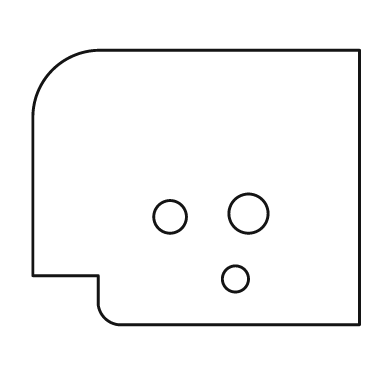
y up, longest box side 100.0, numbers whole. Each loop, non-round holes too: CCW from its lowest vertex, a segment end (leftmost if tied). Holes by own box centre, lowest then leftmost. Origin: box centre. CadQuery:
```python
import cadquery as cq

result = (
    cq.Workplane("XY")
    .moveTo(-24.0, -42.0)
    .lineTo(50.0, -42.0)
    .lineTo(50.0, 42.0)
    .lineTo(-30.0, 42.0)
    .threePointArc((-44.0, 36.0), (-50.0, 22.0))
    .lineTo(-50.0, -27.0)
    .lineTo(-30.0, -27.0)
    .lineTo(-30.0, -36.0)
    .threePointArc((-28.0, -40.0), (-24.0, -42.0))
    .close()
    .moveTo(12.0, -28.0)
    .circle(4.0)
    .moveTo(-8.0, -9.0)
    .circle(5.0)
    .moveTo(16.0, -8.0)
    .circle(6.0)
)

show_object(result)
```